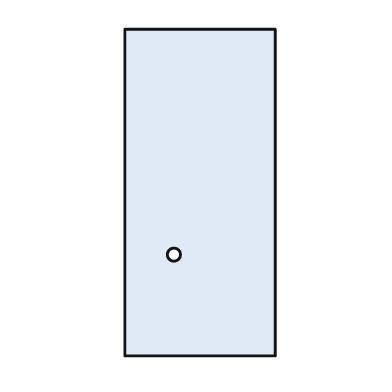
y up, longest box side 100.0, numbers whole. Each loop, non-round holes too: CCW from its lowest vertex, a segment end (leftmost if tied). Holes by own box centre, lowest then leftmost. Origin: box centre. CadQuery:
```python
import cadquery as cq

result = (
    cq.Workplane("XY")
    .moveTo(-23.0, -50.0)
    .lineTo(23.0, -50.0)
    .lineTo(23.0, 50.0)
    .lineTo(-23.0, 50.0)
    .close()
    .moveTo(-8.0, -19.0)
    .circle(2.0)
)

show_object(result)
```